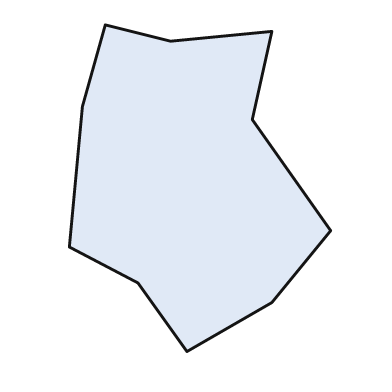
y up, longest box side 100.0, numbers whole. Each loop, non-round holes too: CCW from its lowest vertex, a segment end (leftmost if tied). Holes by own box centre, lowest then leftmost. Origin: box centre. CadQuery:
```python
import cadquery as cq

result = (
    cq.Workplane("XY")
    .moveTo(-4.0, -50.0)
    .lineTo(22.0, -35.0)
    .lineTo(40.0, -13.0)
    .lineTo(16.0, 21.0)
    .lineTo(22.0, 48.0)
    .lineTo(-9.0, 45.0)
    .lineTo(-29.0, 50.0)
    .lineTo(-36.0, 25.0)
    .lineTo(-40.0, -18.0)
    .lineTo(-19.0, -29.0)
    .close()
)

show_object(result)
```